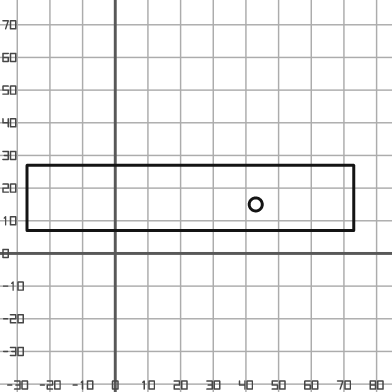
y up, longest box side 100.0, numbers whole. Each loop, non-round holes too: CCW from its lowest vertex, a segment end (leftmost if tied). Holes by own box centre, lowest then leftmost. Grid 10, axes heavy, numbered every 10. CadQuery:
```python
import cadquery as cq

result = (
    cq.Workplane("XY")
    .moveTo(-27.0, 7.0)
    .lineTo(73.0, 7.0)
    .lineTo(73.0, 27.0)
    .lineTo(-27.0, 27.0)
    .close()
    .moveTo(43.0, 15.0)
    .circle(2.0)
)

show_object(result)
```